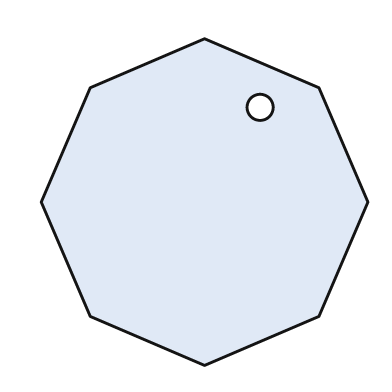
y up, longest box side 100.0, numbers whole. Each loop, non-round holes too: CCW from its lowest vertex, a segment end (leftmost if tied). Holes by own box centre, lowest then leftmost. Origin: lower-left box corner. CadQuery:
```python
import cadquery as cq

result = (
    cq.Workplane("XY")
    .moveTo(50.0, 0.0)
    .lineTo(85.0, 15.0)
    .lineTo(100.0, 50.0)
    .lineTo(85.0, 85.0)
    .lineTo(50.0, 100.0)
    .lineTo(15.0, 85.0)
    .lineTo(0.0, 50.0)
    .lineTo(15.0, 15.0)
    .close()
    .moveTo(67.0, 79.0)
    .circle(4.0)
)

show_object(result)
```